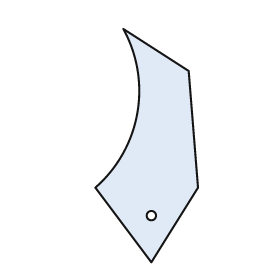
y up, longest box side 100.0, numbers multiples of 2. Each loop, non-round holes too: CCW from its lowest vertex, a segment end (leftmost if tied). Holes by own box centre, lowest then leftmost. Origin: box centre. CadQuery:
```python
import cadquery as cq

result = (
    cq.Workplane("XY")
    .moveTo(2.0, -50.0)
    .lineTo(22.0, -18.0)
    .lineTo(18.0, 32.0)
    .lineTo(-10.0, 50.0)
    .threePointArc((-4.0, 14.0), (-22.0, -18.0))
    .close()
    .moveTo(2.0, -30.0)
    .circle(2.0)
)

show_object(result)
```